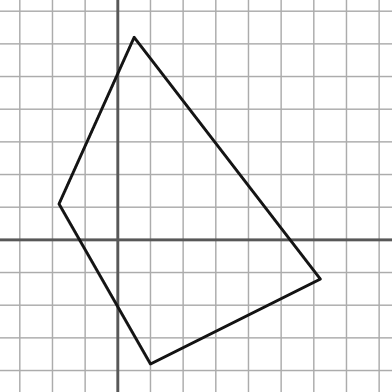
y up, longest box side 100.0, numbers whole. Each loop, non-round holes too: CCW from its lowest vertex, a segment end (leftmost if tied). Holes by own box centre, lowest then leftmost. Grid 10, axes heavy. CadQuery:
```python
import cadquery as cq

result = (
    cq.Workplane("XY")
    .moveTo(10.0, -38.0)
    .lineTo(62.0, -12.0)
    .lineTo(5.0, 62.0)
    .lineTo(-18.0, 11.0)
    .close()
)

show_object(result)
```